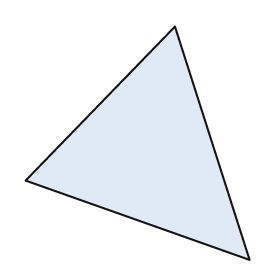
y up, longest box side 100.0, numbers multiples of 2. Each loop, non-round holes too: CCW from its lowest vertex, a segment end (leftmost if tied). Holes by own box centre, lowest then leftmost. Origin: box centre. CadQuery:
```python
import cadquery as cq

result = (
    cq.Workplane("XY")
    .moveTo(48.0, -50.0)
    .lineTo(16.0, 50.0)
    .lineTo(-48.0, -16.0)
    .close()
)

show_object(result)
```